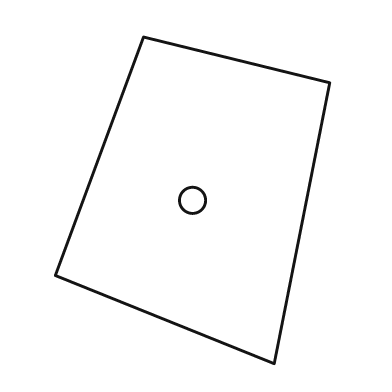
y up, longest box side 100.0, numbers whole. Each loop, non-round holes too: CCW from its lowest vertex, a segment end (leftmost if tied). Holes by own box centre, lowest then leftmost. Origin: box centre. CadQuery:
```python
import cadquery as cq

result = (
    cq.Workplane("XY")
    .moveTo(25.0, -50.0)
    .lineTo(42.0, 36.0)
    .lineTo(-15.0, 50.0)
    .lineTo(-42.0, -23.0)
    .close()
    .moveTo(0.0, 0.0)
    .circle(4.0)
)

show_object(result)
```